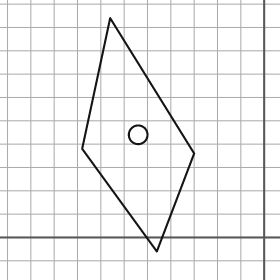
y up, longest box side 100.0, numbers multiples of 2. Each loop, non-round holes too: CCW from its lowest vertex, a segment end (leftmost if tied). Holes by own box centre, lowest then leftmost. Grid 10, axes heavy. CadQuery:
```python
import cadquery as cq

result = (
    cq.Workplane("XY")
    .moveTo(-46.0, -6.0)
    .lineTo(-30.0, 36.0)
    .lineTo(-66.0, 94.0)
    .lineTo(-78.0, 38.0)
    .close()
    .moveTo(-54.0, 44.0)
    .circle(4.0)
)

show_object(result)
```